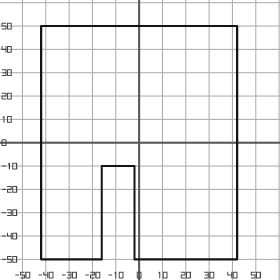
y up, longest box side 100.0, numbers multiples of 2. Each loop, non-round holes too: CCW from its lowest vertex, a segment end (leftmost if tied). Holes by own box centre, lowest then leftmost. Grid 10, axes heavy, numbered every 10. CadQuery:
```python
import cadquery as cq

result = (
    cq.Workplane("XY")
    .moveTo(-42.0, -50.0)
    .lineTo(-16.0, -50.0)
    .lineTo(-16.0, -10.0)
    .lineTo(-2.0, -10.0)
    .lineTo(-2.0, -50.0)
    .lineTo(42.0, -50.0)
    .lineTo(42.0, 50.0)
    .lineTo(-42.0, 50.0)
    .close()
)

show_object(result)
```